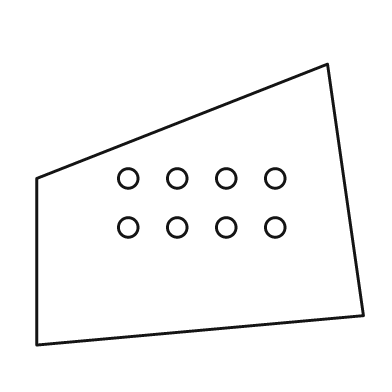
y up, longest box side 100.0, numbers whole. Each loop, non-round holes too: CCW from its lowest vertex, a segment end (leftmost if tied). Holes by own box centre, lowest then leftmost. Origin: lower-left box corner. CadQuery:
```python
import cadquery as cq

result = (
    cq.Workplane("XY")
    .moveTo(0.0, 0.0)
    .lineTo(100.0, 9.0)
    .lineTo(89.0, 86.0)
    .lineTo(0.0, 51.0)
    .close()
    .moveTo(28.0, 36.0)
    .circle(3.0)
    .moveTo(43.0, 36.0)
    .circle(3.0)
    .moveTo(58.0, 36.0)
    .circle(3.0)
    .moveTo(73.0, 36.0)
    .circle(3.0)
    .moveTo(28.0, 51.0)
    .circle(3.0)
    .moveTo(43.0, 51.0)
    .circle(3.0)
    .moveTo(58.0, 51.0)
    .circle(3.0)
    .moveTo(73.0, 51.0)
    .circle(3.0)
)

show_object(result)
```